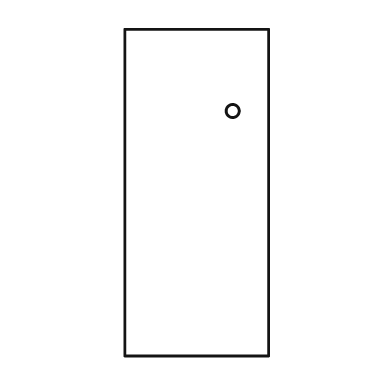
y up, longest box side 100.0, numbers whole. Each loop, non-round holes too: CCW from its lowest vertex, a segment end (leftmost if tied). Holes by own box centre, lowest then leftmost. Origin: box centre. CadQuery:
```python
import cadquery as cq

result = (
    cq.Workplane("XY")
    .moveTo(-22.0, -50.0)
    .lineTo(22.0, -50.0)
    .lineTo(22.0, 50.0)
    .lineTo(-22.0, 50.0)
    .close()
    .moveTo(11.0, 25.0)
    .circle(2.0)
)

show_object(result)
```